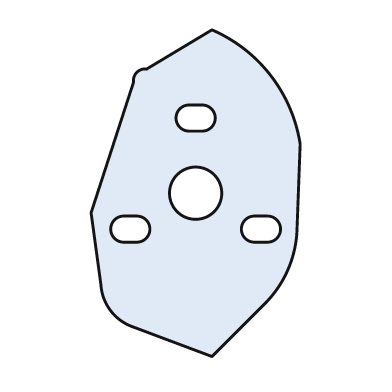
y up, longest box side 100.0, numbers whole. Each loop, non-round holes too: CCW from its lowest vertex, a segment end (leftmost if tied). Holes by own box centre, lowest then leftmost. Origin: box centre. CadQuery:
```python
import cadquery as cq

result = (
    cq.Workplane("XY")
    .moveTo(5.0, -50.0)
    .lineTo(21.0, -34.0)
    .threePointArc((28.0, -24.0), (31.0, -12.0))
    .lineTo(32.0, 15.0)
    .threePointArc((23.0, 36.0), (5.0, 50.0))
    .lineTo(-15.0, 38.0)
    .threePointArc((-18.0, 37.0), (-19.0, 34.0))
    .lineTo(-32.0, -6.0)
    .lineTo(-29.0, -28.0)
    .threePointArc((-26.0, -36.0), (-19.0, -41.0))
    .close()
    .moveTo(-22.0, -15.0)
    .lineTo(-18.0, -15.0)
    .threePointArc((-14.0, -11.0), (-18.0, -7.0))
    .lineTo(-22.0, -7.0)
    .threePointArc((-26.0, -11.0), (-22.0, -15.0))
    .close()
    .moveTo(18.0, -15.0)
    .lineTo(22.0, -15.0)
    .threePointArc((26.0, -11.0), (22.0, -7.0))
    .lineTo(18.0, -7.0)
    .threePointArc((14.0, -11.0), (18.0, -15.0))
    .close()
    .moveTo(0.0, 0.0)
    .circle(8.0)
    .moveTo(-2.0, 19.0)
    .lineTo(2.0, 19.0)
    .threePointArc((6.0, 23.0), (2.0, 27.0))
    .lineTo(-2.0, 27.0)
    .threePointArc((-6.0, 23.0), (-2.0, 19.0))
    .close()
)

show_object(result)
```